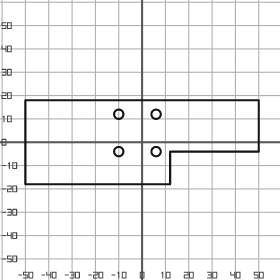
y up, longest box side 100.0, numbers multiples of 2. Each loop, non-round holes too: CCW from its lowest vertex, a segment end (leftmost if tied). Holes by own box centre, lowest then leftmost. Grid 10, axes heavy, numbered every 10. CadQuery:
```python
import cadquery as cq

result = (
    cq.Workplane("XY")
    .moveTo(-50.0, -18.0)
    .lineTo(12.0, -18.0)
    .lineTo(12.0, -4.0)
    .lineTo(50.0, -4.0)
    .lineTo(50.0, 18.0)
    .lineTo(-50.0, 18.0)
    .close()
    .moveTo(-10.0, -4.0)
    .circle(2.0)
    .moveTo(6.0, -4.0)
    .circle(2.0)
    .moveTo(-10.0, 12.0)
    .circle(2.0)
    .moveTo(6.0, 12.0)
    .circle(2.0)
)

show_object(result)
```